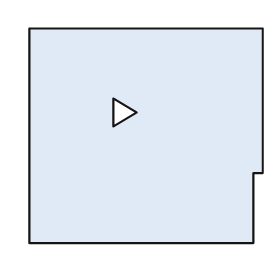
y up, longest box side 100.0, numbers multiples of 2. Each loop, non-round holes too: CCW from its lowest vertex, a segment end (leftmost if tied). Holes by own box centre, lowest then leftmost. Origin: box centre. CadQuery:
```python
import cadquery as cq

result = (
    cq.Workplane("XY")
    .moveTo(-50.0, -46.0)
    .lineTo(46.0, -46.0)
    .lineTo(46.0, -16.0)
    .lineTo(50.0, -16.0)
    .lineTo(50.0, 46.0)
    .lineTo(-50.0, 46.0)
    .close()
    .moveTo(-14.0, 4.0)
    .lineTo(-4.0, 10.0)
    .lineTo(-14.0, 16.0)
    .close()
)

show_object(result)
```